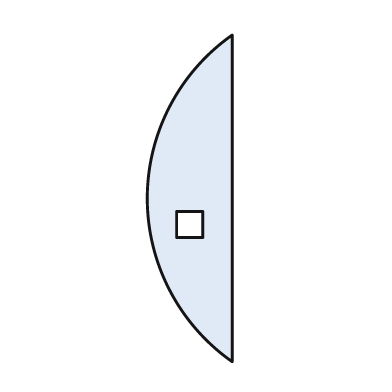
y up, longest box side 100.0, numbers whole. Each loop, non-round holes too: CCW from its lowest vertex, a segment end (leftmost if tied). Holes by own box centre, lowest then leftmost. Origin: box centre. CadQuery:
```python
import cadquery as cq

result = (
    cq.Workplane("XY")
    .moveTo(13.0, -50.0)
    .lineTo(13.0, 50.0)
    .threePointArc((-13.0, 0.0), (13.0, -50.0))
    .close()
    .moveTo(-4.0, -12.0)
    .lineTo(4.0, -12.0)
    .lineTo(4.0, -4.0)
    .lineTo(-4.0, -4.0)
    .close()
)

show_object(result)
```